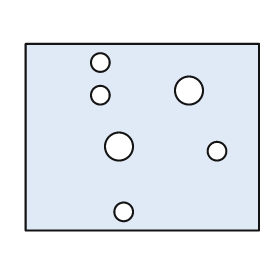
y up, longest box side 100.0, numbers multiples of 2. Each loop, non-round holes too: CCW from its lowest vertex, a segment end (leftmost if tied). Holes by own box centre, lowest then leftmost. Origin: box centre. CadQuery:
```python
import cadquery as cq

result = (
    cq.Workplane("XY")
    .moveTo(-50.0, -40.0)
    .lineTo(50.0, -40.0)
    .lineTo(50.0, 40.0)
    .lineTo(-50.0, 40.0)
    .close()
    .moveTo(-8.0, -32.0)
    .circle(4.0)
    .moveTo(32.0, -6.0)
    .circle(4.0)
    .moveTo(-10.0, -4.0)
    .circle(6.0)
    .moveTo(-18.0, 18.0)
    .circle(4.0)
    .moveTo(20.0, 20.0)
    .circle(6.0)
    .moveTo(-18.0, 32.0)
    .circle(4.0)
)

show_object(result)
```